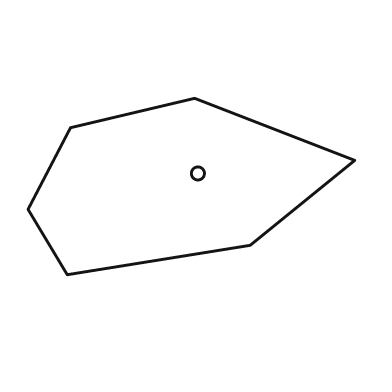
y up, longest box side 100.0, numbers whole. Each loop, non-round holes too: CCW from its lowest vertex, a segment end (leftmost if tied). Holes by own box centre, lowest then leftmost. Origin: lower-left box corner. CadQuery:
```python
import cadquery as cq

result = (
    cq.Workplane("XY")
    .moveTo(12.0, 0.0)
    .lineTo(68.0, 9.0)
    .lineTo(100.0, 35.0)
    .lineTo(51.0, 54.0)
    .lineTo(13.0, 45.0)
    .lineTo(0.0, 20.0)
    .close()
    .moveTo(52.0, 31.0)
    .circle(2.0)
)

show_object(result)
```